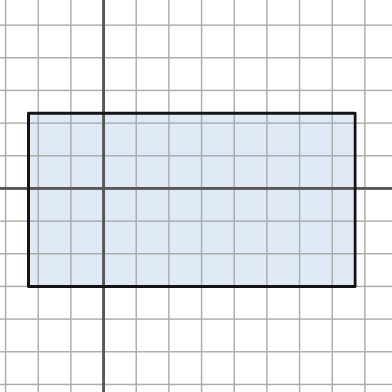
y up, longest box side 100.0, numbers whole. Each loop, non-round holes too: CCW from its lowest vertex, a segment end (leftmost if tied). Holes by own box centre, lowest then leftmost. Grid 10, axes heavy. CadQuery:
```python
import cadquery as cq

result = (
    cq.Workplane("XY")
    .moveTo(-23.0, -30.0)
    .lineTo(77.0, -30.0)
    .lineTo(77.0, 23.0)
    .lineTo(-23.0, 23.0)
    .close()
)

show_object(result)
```